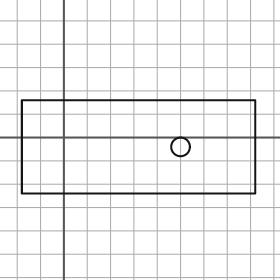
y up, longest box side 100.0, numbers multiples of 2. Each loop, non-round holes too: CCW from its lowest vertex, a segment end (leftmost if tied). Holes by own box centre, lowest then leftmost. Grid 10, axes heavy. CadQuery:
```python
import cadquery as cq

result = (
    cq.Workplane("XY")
    .moveTo(-18.0, -24.0)
    .lineTo(82.0, -24.0)
    .lineTo(82.0, 16.0)
    .lineTo(-18.0, 16.0)
    .close()
    .moveTo(50.0, -4.0)
    .circle(4.0)
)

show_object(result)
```